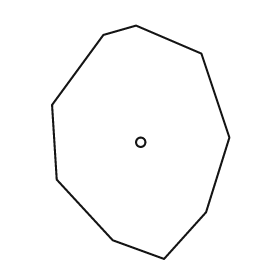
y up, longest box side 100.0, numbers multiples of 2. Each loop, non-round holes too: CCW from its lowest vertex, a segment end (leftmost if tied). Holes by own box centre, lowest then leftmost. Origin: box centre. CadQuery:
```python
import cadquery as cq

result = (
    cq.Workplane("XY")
    .moveTo(10.0, -50.0)
    .lineTo(28.0, -30.0)
    .lineTo(38.0, 2.0)
    .lineTo(26.0, 38.0)
    .lineTo(-2.0, 50.0)
    .lineTo(-16.0, 46.0)
    .lineTo(-38.0, 16.0)
    .lineTo(-36.0, -16.0)
    .lineTo(-12.0, -42.0)
    .close()
    .moveTo(0.0, 0.0)
    .circle(2.0)
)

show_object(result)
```